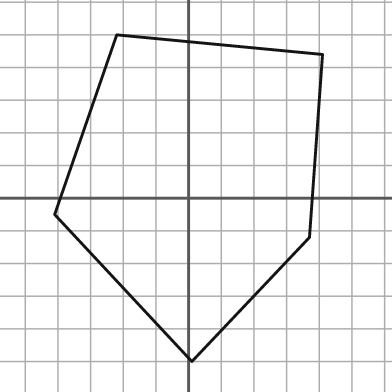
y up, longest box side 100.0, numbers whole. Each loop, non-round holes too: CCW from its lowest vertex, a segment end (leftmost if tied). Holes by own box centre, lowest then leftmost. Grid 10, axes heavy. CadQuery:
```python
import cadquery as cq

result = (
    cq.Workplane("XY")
    .moveTo(1.0, -50.0)
    .lineTo(37.0, -12.0)
    .lineTo(41.0, 44.0)
    .lineTo(-22.0, 50.0)
    .lineTo(-41.0, -5.0)
    .close()
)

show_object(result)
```